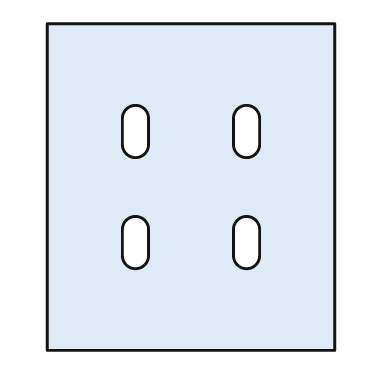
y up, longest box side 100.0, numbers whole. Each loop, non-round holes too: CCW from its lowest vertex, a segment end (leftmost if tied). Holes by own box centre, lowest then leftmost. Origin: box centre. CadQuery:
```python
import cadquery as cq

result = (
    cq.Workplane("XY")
    .moveTo(-44.0, -50.0)
    .lineTo(44.0, -50.0)
    .lineTo(44.0, 50.0)
    .lineTo(-44.0, 50.0)
    .close()
    .moveTo(-21.0, -21.0)
    .threePointArc((-17.0, -25.0), (-13.0, -21.0))
    .lineTo(-13.0, -13.0)
    .threePointArc((-17.0, -9.0), (-21.0, -13.0))
    .close()
    .moveTo(13.0, -21.0)
    .threePointArc((17.0, -25.0), (21.0, -21.0))
    .lineTo(21.0, -13.0)
    .threePointArc((17.0, -9.0), (13.0, -13.0))
    .close()
    .moveTo(-21.0, 13.0)
    .threePointArc((-17.0, 9.0), (-13.0, 13.0))
    .lineTo(-13.0, 21.0)
    .threePointArc((-17.0, 25.0), (-21.0, 21.0))
    .close()
    .moveTo(13.0, 13.0)
    .threePointArc((17.0, 9.0), (21.0, 13.0))
    .lineTo(21.0, 21.0)
    .threePointArc((17.0, 25.0), (13.0, 21.0))
    .close()
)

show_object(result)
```